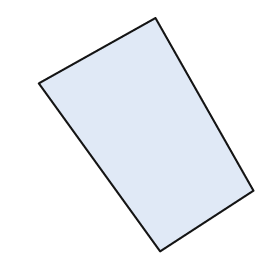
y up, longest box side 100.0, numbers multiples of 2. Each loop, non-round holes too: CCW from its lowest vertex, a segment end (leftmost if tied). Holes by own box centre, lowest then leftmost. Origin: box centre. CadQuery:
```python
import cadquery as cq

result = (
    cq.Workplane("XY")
    .moveTo(6.0, -50.0)
    .lineTo(46.0, -24.0)
    .lineTo(4.0, 50.0)
    .lineTo(-46.0, 22.0)
    .close()
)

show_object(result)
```